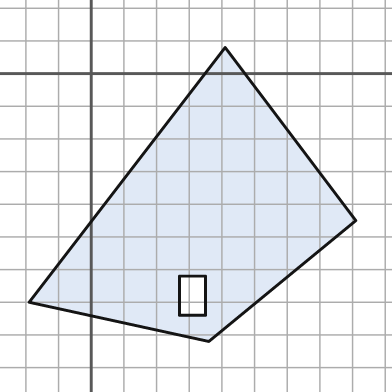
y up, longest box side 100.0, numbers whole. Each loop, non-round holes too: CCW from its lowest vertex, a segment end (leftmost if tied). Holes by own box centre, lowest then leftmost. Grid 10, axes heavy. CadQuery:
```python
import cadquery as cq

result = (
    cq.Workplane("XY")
    .moveTo(36.0, -82.0)
    .lineTo(81.0, -45.0)
    .lineTo(41.0, 8.0)
    .lineTo(-19.0, -70.0)
    .close()
    .moveTo(27.0, -74.0)
    .lineTo(35.0, -74.0)
    .lineTo(35.0, -62.0)
    .lineTo(27.0, -62.0)
    .close()
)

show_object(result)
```